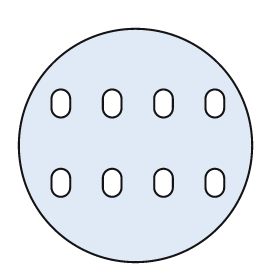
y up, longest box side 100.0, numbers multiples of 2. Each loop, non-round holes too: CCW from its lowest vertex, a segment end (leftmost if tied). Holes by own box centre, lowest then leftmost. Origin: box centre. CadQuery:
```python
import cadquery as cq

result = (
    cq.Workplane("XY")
    .moveTo(0.0, 0.0)
    .circle(50.0)
    .moveTo(-36.0, -18.0)
    .threePointArc((-32.0, -22.0), (-28.0, -18.0))
    .lineTo(-28.0, -14.0)
    .threePointArc((-32.0, -10.0), (-36.0, -14.0))
    .close()
    .moveTo(-14.0, -18.0)
    .threePointArc((-10.0, -22.0), (-6.0, -18.0))
    .lineTo(-6.0, -14.0)
    .threePointArc((-10.0, -10.0), (-14.0, -14.0))
    .close()
    .moveTo(8.0, -18.0)
    .threePointArc((12.0, -22.0), (16.0, -18.0))
    .lineTo(16.0, -14.0)
    .threePointArc((12.0, -10.0), (8.0, -14.0))
    .close()
    .moveTo(30.0, -18.0)
    .threePointArc((34.0, -22.0), (38.0, -18.0))
    .lineTo(38.0, -14.0)
    .threePointArc((34.0, -10.0), (30.0, -14.0))
    .close()
    .moveTo(-36.0, 16.0)
    .threePointArc((-32.0, 12.0), (-28.0, 16.0))
    .lineTo(-28.0, 20.0)
    .threePointArc((-32.0, 24.0), (-36.0, 20.0))
    .close()
    .moveTo(-14.0, 16.0)
    .threePointArc((-10.0, 12.0), (-6.0, 16.0))
    .lineTo(-6.0, 20.0)
    .threePointArc((-10.0, 24.0), (-14.0, 20.0))
    .close()
    .moveTo(8.0, 16.0)
    .threePointArc((12.0, 12.0), (16.0, 16.0))
    .lineTo(16.0, 20.0)
    .threePointArc((12.0, 24.0), (8.0, 20.0))
    .close()
    .moveTo(30.0, 16.0)
    .threePointArc((34.0, 12.0), (38.0, 16.0))
    .lineTo(38.0, 20.0)
    .threePointArc((34.0, 24.0), (30.0, 20.0))
    .close()
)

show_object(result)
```